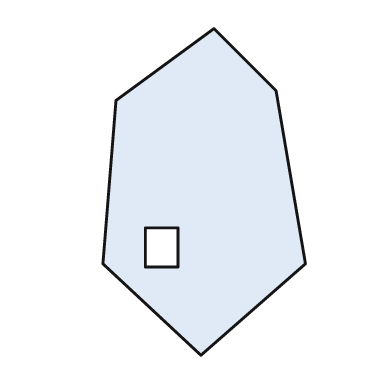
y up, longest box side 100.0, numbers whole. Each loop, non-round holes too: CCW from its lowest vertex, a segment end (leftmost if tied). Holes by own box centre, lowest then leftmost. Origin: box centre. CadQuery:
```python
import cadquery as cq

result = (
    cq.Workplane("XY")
    .moveTo(-1.0, -50.0)
    .lineTo(31.0, -22.0)
    .lineTo(22.0, 31.0)
    .lineTo(3.0, 50.0)
    .lineTo(-27.0, 28.0)
    .lineTo(-31.0, -22.0)
    .close()
    .moveTo(-18.0, -23.0)
    .lineTo(-8.0, -23.0)
    .lineTo(-8.0, -11.0)
    .lineTo(-18.0, -11.0)
    .close()
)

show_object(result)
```